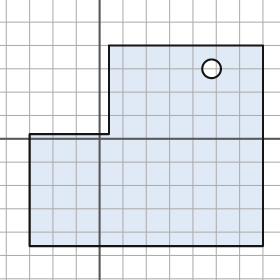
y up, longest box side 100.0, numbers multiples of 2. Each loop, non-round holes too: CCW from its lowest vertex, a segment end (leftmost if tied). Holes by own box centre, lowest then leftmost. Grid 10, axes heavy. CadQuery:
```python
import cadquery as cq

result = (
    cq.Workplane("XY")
    .moveTo(-30.0, -46.0)
    .lineTo(70.0, -46.0)
    .lineTo(70.0, 40.0)
    .lineTo(4.0, 40.0)
    .lineTo(4.0, 2.0)
    .lineTo(-30.0, 2.0)
    .close()
    .moveTo(48.0, 30.0)
    .circle(4.0)
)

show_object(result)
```